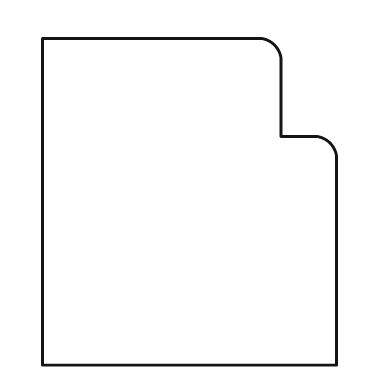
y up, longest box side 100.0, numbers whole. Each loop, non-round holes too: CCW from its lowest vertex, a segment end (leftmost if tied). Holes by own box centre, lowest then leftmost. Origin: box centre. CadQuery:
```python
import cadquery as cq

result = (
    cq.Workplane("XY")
    .moveTo(-45.0, -50.0)
    .lineTo(45.0, -50.0)
    .lineTo(45.0, 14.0)
    .threePointArc((43.0, 18.0), (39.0, 20.0))
    .lineTo(28.0, 20.0)
    .lineTo(28.0, 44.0)
    .threePointArc((26.0, 48.0), (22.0, 50.0))
    .lineTo(-45.0, 50.0)
    .close()
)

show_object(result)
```